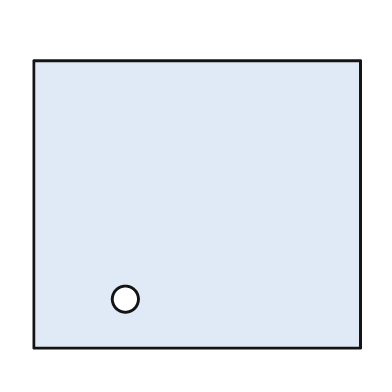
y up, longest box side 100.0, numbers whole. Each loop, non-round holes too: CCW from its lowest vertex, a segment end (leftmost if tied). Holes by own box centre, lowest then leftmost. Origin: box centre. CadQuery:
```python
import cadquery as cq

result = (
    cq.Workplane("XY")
    .moveTo(-50.0, -44.0)
    .lineTo(50.0, -44.0)
    .lineTo(50.0, 44.0)
    .lineTo(-50.0, 44.0)
    .close()
    .moveTo(-22.0, -29.0)
    .circle(4.0)
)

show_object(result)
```